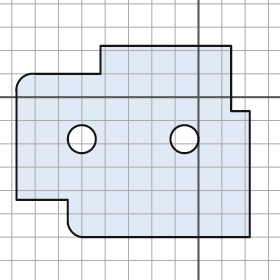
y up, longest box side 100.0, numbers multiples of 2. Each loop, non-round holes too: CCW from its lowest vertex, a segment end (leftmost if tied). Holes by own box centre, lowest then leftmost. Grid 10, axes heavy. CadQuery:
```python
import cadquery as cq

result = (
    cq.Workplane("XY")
    .moveTo(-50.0, -60.0)
    .lineTo(22.0, -60.0)
    .lineTo(22.0, -6.0)
    .lineTo(14.0, -6.0)
    .lineTo(14.0, 22.0)
    .lineTo(-42.0, 22.0)
    .lineTo(-42.0, 10.0)
    .lineTo(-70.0, 10.0)
    .threePointArc((-76.0, 8.0), (-78.0, 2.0))
    .lineTo(-78.0, -44.0)
    .lineTo(-56.0, -44.0)
    .lineTo(-56.0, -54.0)
    .threePointArc((-54.0, -58.0), (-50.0, -60.0))
    .close()
    .moveTo(-50.0, -18.0)
    .circle(6.0)
    .moveTo(-6.0, -18.0)
    .circle(6.0)
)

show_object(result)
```